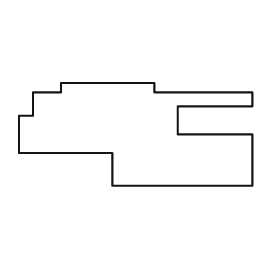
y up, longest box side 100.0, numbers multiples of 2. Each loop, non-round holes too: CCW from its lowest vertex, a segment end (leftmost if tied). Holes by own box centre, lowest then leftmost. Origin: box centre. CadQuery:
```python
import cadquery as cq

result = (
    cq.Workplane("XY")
    .moveTo(-10.0, -22.0)
    .lineTo(50.0, -22.0)
    .lineTo(50.0, 0.0)
    .lineTo(18.0, 0.0)
    .lineTo(18.0, 12.0)
    .lineTo(50.0, 12.0)
    .lineTo(50.0, 18.0)
    .lineTo(8.0, 18.0)
    .lineTo(8.0, 22.0)
    .lineTo(-32.0, 22.0)
    .lineTo(-32.0, 18.0)
    .lineTo(-44.0, 18.0)
    .lineTo(-44.0, 8.0)
    .lineTo(-50.0, 8.0)
    .lineTo(-50.0, -8.0)
    .lineTo(-10.0, -8.0)
    .close()
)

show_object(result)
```